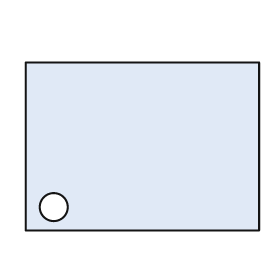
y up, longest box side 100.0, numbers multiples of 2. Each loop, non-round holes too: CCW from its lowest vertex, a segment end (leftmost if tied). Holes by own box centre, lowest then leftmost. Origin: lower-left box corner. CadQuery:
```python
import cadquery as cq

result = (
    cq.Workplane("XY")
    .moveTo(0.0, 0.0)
    .lineTo(100.0, 0.0)
    .lineTo(100.0, 72.0)
    .lineTo(0.0, 72.0)
    .close()
    .moveTo(12.0, 10.0)
    .circle(6.0)
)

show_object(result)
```